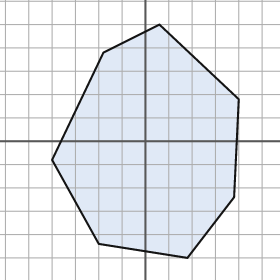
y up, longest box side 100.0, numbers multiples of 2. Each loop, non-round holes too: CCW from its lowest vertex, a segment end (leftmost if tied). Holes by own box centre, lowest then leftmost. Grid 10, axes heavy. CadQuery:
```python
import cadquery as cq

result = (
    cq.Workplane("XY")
    .moveTo(18.0, -50.0)
    .lineTo(38.0, -24.0)
    .lineTo(40.0, 18.0)
    .lineTo(6.0, 50.0)
    .lineTo(-18.0, 38.0)
    .lineTo(-40.0, -8.0)
    .lineTo(-20.0, -44.0)
    .close()
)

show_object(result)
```